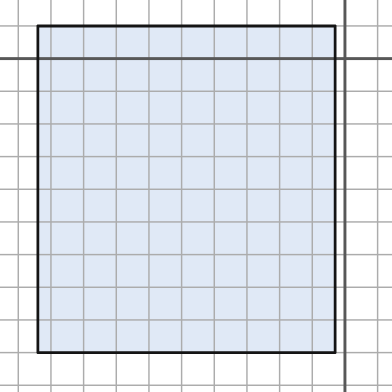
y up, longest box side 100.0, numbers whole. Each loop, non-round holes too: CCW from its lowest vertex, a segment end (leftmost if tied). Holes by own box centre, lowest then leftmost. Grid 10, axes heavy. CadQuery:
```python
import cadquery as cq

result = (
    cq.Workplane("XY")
    .moveTo(-94.0, -90.0)
    .lineTo(-3.0, -90.0)
    .lineTo(-3.0, 10.0)
    .lineTo(-94.0, 10.0)
    .close()
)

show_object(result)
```